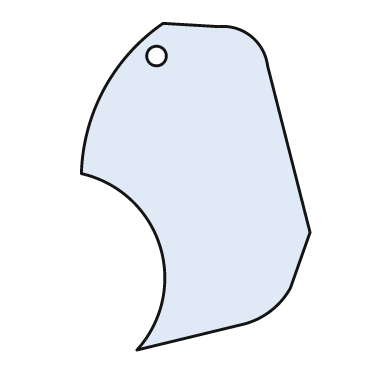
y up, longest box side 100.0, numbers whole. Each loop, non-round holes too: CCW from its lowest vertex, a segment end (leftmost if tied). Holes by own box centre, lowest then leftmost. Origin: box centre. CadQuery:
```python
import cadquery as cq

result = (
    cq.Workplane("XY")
    .moveTo(-18.0, -50.0)
    .lineTo(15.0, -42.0)
    .threePointArc((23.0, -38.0), (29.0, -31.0))
    .lineTo(35.0, -14.0)
    .lineTo(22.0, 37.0)
    .threePointArc((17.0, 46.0), (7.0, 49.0))
    .lineTo(-10.0, 50.0)
    .threePointArc((-28.0, 30.0), (-35.0, 4.0))
    .threePointArc((-11.0, -18.0), (-18.0, -50.0))
    .close()
    .moveTo(-12.0, 40.0)
    .circle(3.0)
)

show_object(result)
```